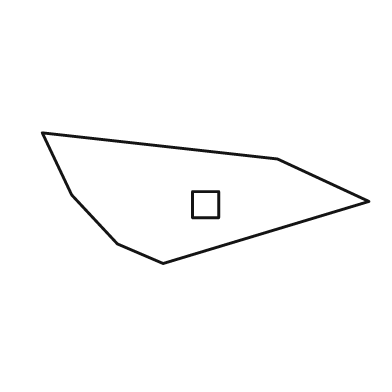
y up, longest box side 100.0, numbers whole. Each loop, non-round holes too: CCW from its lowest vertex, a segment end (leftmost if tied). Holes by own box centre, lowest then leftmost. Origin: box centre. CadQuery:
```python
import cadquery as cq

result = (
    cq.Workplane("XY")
    .moveTo(-13.0, -20.0)
    .lineTo(50.0, -1.0)
    .lineTo(22.0, 12.0)
    .lineTo(-50.0, 20.0)
    .lineTo(-41.0, 1.0)
    .lineTo(-27.0, -14.0)
    .close()
    .moveTo(-4.0, -6.0)
    .lineTo(4.0, -6.0)
    .lineTo(4.0, 2.0)
    .lineTo(-4.0, 2.0)
    .close()
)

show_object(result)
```